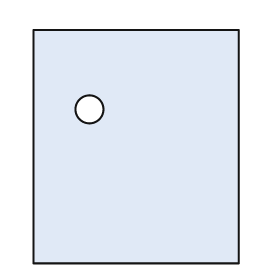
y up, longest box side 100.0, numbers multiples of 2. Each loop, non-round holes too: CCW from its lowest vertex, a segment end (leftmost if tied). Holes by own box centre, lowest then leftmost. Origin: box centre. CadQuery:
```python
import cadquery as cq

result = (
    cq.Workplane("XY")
    .moveTo(-44.0, -50.0)
    .lineTo(44.0, -50.0)
    .lineTo(44.0, 50.0)
    .lineTo(-44.0, 50.0)
    .close()
    .moveTo(-20.0, 16.0)
    .circle(6.0)
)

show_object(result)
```